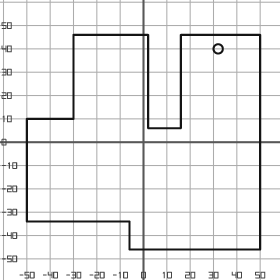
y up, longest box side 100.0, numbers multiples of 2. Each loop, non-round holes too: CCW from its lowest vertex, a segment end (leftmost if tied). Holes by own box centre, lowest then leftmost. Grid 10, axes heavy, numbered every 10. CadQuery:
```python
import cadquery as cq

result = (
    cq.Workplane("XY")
    .moveTo(-6.0, -46.0)
    .lineTo(50.0, -46.0)
    .lineTo(50.0, 46.0)
    .lineTo(16.0, 46.0)
    .lineTo(16.0, 6.0)
    .lineTo(2.0, 6.0)
    .lineTo(2.0, 46.0)
    .lineTo(-30.0, 46.0)
    .lineTo(-30.0, 10.0)
    .lineTo(-50.0, 10.0)
    .lineTo(-50.0, -34.0)
    .lineTo(-6.0, -34.0)
    .close()
    .moveTo(32.0, 40.0)
    .circle(2.0)
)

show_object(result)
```